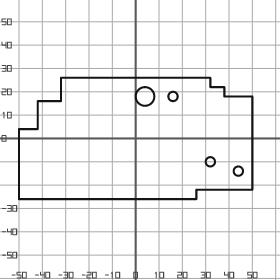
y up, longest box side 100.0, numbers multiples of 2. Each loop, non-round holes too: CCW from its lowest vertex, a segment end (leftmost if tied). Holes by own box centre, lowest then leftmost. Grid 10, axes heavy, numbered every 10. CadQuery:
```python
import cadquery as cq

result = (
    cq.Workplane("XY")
    .moveTo(-50.0, -26.0)
    .lineTo(26.0, -26.0)
    .lineTo(26.0, -22.0)
    .lineTo(50.0, -22.0)
    .lineTo(50.0, 18.0)
    .lineTo(38.0, 18.0)
    .lineTo(38.0, 22.0)
    .lineTo(32.0, 22.0)
    .lineTo(32.0, 26.0)
    .lineTo(-32.0, 26.0)
    .lineTo(-32.0, 16.0)
    .lineTo(-42.0, 16.0)
    .lineTo(-42.0, 4.0)
    .lineTo(-50.0, 4.0)
    .close()
    .moveTo(44.0, -14.0)
    .circle(2.0)
    .moveTo(32.0, -10.0)
    .circle(2.0)
    .moveTo(4.0, 18.0)
    .circle(4.0)
    .moveTo(16.0, 18.0)
    .circle(2.0)
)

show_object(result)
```